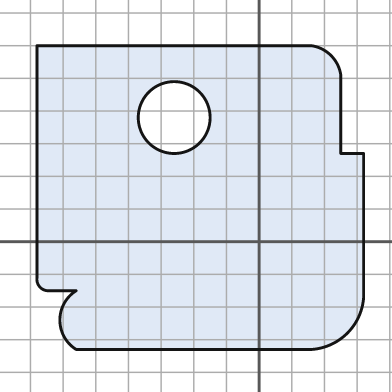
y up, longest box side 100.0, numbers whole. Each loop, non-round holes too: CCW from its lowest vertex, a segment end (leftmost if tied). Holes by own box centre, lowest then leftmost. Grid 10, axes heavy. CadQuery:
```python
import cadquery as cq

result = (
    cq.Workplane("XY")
    .moveTo(-56.0, -33.0)
    .lineTo(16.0, -33.0)
    .threePointArc((27.0, -28.0), (32.0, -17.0))
    .lineTo(32.0, 27.0)
    .lineTo(25.0, 27.0)
    .lineTo(25.0, 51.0)
    .threePointArc((22.0, 57.0), (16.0, 60.0))
    .lineTo(-68.0, 60.0)
    .lineTo(-68.0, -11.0)
    .threePointArc((-67.0, -14.0), (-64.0, -15.0))
    .lineTo(-56.0, -15.0)
    .threePointArc((-61.0, -24.0), (-56.0, -33.0))
    .close()
    .moveTo(-26.0, 38.0)
    .circle(11.0)
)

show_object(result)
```